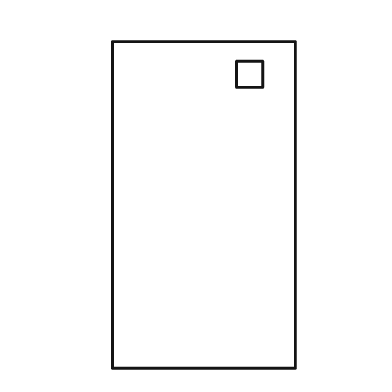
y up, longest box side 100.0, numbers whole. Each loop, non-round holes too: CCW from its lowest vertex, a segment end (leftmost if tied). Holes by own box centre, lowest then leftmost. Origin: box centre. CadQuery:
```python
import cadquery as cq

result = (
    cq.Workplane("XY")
    .moveTo(-28.0, -50.0)
    .lineTo(28.0, -50.0)
    .lineTo(28.0, 50.0)
    .lineTo(-28.0, 50.0)
    .close()
    .moveTo(10.0, 36.0)
    .lineTo(18.0, 36.0)
    .lineTo(18.0, 44.0)
    .lineTo(10.0, 44.0)
    .close()
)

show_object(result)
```